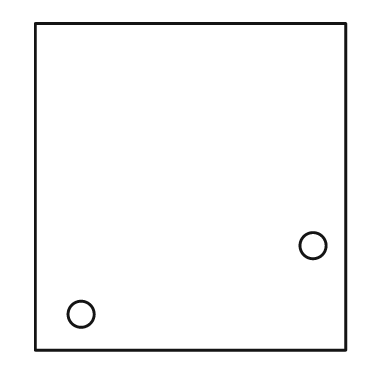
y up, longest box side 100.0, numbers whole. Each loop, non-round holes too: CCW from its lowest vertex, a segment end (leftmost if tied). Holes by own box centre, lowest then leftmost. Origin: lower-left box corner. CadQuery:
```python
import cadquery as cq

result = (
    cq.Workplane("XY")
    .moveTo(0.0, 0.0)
    .lineTo(95.0, 0.0)
    .lineTo(95.0, 100.0)
    .lineTo(0.0, 100.0)
    .close()
    .moveTo(14.0, 11.0)
    .circle(4.0)
    .moveTo(85.0, 32.0)
    .circle(4.0)
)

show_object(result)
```